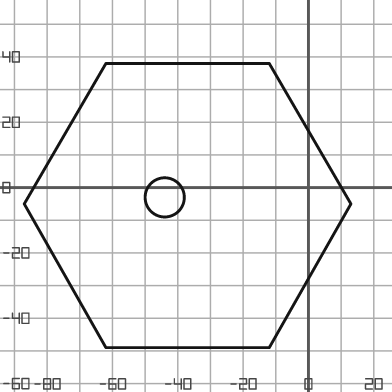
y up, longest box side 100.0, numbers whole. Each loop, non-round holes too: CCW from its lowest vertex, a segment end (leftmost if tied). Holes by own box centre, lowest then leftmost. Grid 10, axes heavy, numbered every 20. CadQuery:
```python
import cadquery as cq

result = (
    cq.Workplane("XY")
    .moveTo(-62.0, -49.0)
    .lineTo(-12.0, -49.0)
    .lineTo(13.0, -5.0)
    .lineTo(-12.0, 38.0)
    .lineTo(-62.0, 38.0)
    .lineTo(-87.0, -5.0)
    .close()
    .moveTo(-44.0, -3.0)
    .circle(6.0)
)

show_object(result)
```